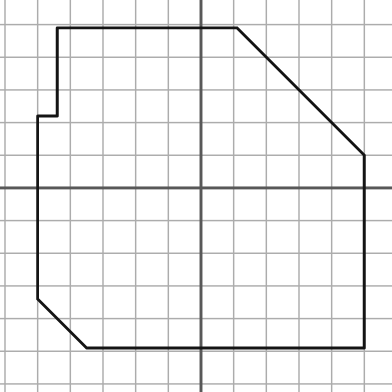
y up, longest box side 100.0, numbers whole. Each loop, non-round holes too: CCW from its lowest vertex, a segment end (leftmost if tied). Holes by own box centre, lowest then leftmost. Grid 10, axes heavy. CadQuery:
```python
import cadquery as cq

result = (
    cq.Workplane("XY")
    .moveTo(-35.0, -49.0)
    .lineTo(50.0, -49.0)
    .lineTo(50.0, 10.0)
    .lineTo(11.0, 49.0)
    .lineTo(-44.0, 49.0)
    .lineTo(-44.0, 22.0)
    .lineTo(-50.0, 22.0)
    .lineTo(-50.0, -34.0)
    .close()
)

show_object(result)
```